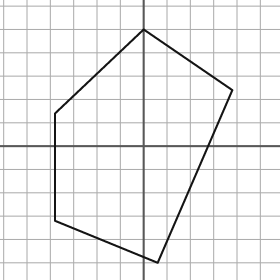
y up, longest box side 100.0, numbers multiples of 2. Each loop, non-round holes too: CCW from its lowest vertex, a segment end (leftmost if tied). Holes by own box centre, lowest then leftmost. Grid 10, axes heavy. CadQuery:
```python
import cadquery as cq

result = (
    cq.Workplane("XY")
    .moveTo(6.0, -50.0)
    .lineTo(38.0, 24.0)
    .lineTo(0.0, 50.0)
    .lineTo(-38.0, 14.0)
    .lineTo(-38.0, -32.0)
    .close()
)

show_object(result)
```